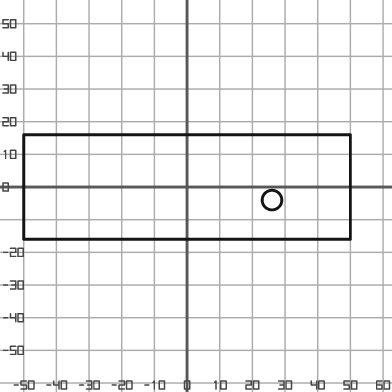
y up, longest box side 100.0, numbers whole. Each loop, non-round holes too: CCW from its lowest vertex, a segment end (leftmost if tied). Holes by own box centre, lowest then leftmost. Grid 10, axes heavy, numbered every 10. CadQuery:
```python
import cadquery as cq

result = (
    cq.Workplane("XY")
    .moveTo(-50.0, -16.0)
    .lineTo(50.0, -16.0)
    .lineTo(50.0, 16.0)
    .lineTo(-50.0, 16.0)
    .close()
    .moveTo(26.0, -4.0)
    .circle(3.0)
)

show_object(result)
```